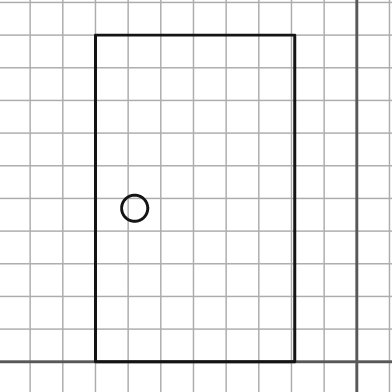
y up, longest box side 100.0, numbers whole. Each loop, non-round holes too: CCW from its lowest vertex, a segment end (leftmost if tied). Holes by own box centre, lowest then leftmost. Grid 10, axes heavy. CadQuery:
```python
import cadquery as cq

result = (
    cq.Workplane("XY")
    .moveTo(-80.0, 0.0)
    .lineTo(-19.0, 0.0)
    .lineTo(-19.0, 100.0)
    .lineTo(-80.0, 100.0)
    .close()
    .moveTo(-68.0, 47.0)
    .circle(4.0)
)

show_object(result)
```